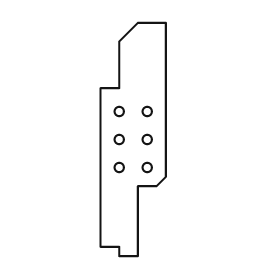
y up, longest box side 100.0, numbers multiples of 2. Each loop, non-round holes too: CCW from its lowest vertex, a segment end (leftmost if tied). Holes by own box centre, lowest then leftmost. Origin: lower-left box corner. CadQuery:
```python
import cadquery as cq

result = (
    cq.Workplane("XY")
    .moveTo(8.0, 0.0)
    .lineTo(16.0, 0.0)
    .lineTo(16.0, 30.0)
    .lineTo(24.0, 30.0)
    .lineTo(28.0, 34.0)
    .lineTo(28.0, 100.0)
    .lineTo(16.0, 100.0)
    .lineTo(8.0, 92.0)
    .lineTo(8.0, 72.0)
    .lineTo(0.0, 72.0)
    .lineTo(0.0, 4.0)
    .lineTo(8.0, 4.0)
    .close()
    .moveTo(8.0, 38.0)
    .circle(2.0)
    .moveTo(20.0, 38.0)
    .circle(2.0)
    .moveTo(8.0, 50.0)
    .circle(2.0)
    .moveTo(20.0, 50.0)
    .circle(2.0)
    .moveTo(8.0, 62.0)
    .circle(2.0)
    .moveTo(20.0, 62.0)
    .circle(2.0)
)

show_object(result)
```